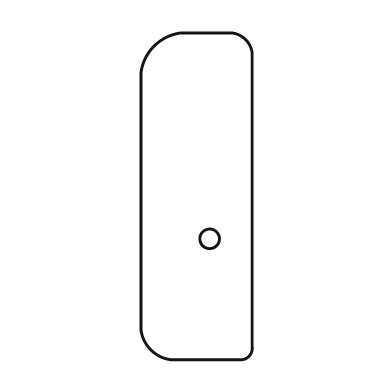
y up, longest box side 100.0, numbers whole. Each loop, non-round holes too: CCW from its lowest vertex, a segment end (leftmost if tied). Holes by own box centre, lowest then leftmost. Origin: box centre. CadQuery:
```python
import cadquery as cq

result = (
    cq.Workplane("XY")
    .moveTo(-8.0, -50.0)
    .lineTo(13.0, -50.0)
    .threePointArc((16.0, -49.0), (17.0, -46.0))
    .lineTo(17.0, 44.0)
    .threePointArc((15.0, 48.0), (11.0, 50.0))
    .lineTo(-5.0, 50.0)
    .threePointArc((-13.0, 46.0), (-17.0, 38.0))
    .lineTo(-17.0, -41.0)
    .threePointArc((-14.0, -47.0), (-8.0, -50.0))
    .close()
    .moveTo(4.0, -13.0)
    .circle(3.0)
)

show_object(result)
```